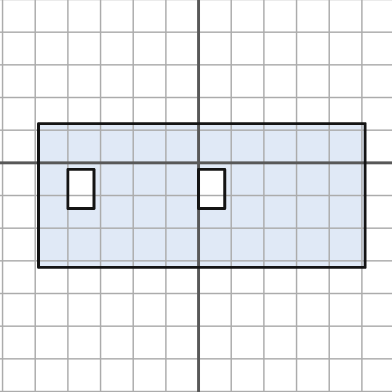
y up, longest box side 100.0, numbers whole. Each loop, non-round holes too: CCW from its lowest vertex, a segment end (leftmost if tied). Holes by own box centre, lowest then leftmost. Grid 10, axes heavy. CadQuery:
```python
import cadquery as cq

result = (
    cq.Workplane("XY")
    .moveTo(-49.0, -32.0)
    .lineTo(51.0, -32.0)
    .lineTo(51.0, 12.0)
    .lineTo(-49.0, 12.0)
    .close()
    .moveTo(-40.0, -14.0)
    .lineTo(-32.0, -14.0)
    .lineTo(-32.0, -2.0)
    .lineTo(-40.0, -2.0)
    .close()
    .moveTo(0.0, -14.0)
    .lineTo(8.0, -14.0)
    .lineTo(8.0, -2.0)
    .lineTo(0.0, -2.0)
    .close()
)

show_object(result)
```